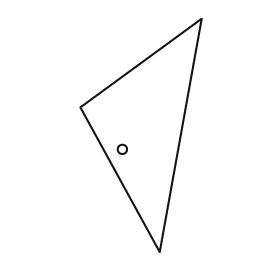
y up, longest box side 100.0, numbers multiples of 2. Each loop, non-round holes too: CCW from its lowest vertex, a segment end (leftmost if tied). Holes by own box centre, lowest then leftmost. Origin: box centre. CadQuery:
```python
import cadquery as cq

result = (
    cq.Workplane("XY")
    .moveTo(8.0, -50.0)
    .lineTo(26.0, 50.0)
    .lineTo(-26.0, 12.0)
    .close()
    .moveTo(-8.0, -6.0)
    .circle(2.0)
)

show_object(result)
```